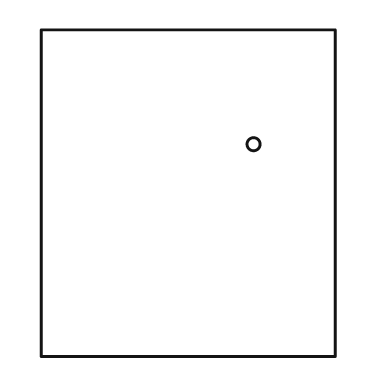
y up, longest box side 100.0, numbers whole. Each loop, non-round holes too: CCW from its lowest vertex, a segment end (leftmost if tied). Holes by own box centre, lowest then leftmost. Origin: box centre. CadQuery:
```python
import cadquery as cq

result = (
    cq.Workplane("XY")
    .moveTo(-45.0, -50.0)
    .lineTo(45.0, -50.0)
    .lineTo(45.0, 50.0)
    .lineTo(-45.0, 50.0)
    .close()
    .moveTo(20.0, 15.0)
    .circle(2.0)
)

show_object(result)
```